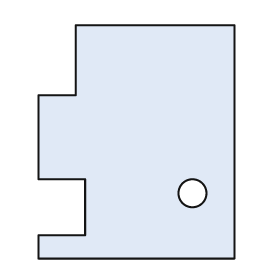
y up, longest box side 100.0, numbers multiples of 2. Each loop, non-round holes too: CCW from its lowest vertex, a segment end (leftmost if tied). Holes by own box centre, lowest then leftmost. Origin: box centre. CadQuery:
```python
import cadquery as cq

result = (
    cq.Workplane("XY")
    .moveTo(-42.0, -50.0)
    .lineTo(42.0, -50.0)
    .lineTo(42.0, 50.0)
    .lineTo(-26.0, 50.0)
    .lineTo(-26.0, 20.0)
    .lineTo(-42.0, 20.0)
    .lineTo(-42.0, -16.0)
    .lineTo(-22.0, -16.0)
    .lineTo(-22.0, -40.0)
    .lineTo(-42.0, -40.0)
    .close()
    .moveTo(24.0, -22.0)
    .circle(6.0)
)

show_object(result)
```